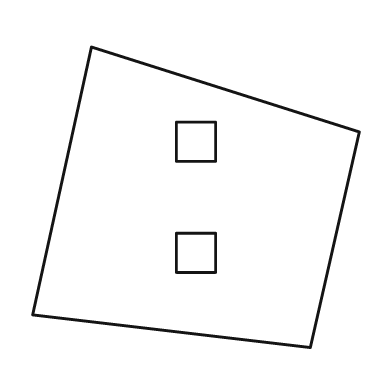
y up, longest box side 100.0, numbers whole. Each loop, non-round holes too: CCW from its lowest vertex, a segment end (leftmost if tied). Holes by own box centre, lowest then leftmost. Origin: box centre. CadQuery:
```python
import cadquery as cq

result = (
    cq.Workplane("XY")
    .moveTo(35.0, -46.0)
    .lineTo(50.0, 20.0)
    .lineTo(-32.0, 46.0)
    .lineTo(-50.0, -36.0)
    .close()
    .moveTo(-6.0, -23.0)
    .lineTo(6.0, -23.0)
    .lineTo(6.0, -11.0)
    .lineTo(-6.0, -11.0)
    .close()
    .moveTo(-6.0, 11.0)
    .lineTo(6.0, 11.0)
    .lineTo(6.0, 23.0)
    .lineTo(-6.0, 23.0)
    .close()
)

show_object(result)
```